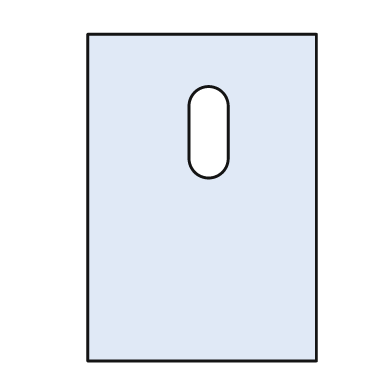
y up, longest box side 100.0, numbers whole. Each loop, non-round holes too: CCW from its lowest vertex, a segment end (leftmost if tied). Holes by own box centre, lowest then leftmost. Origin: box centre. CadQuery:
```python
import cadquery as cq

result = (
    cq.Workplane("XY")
    .moveTo(-35.0, -50.0)
    .lineTo(35.0, -50.0)
    .lineTo(35.0, 50.0)
    .lineTo(-35.0, 50.0)
    .close()
    .moveTo(-4.0, 12.0)
    .threePointArc((2.0, 6.0), (8.0, 12.0))
    .lineTo(8.0, 28.0)
    .threePointArc((2.0, 34.0), (-4.0, 28.0))
    .close()
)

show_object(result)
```